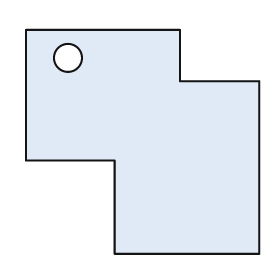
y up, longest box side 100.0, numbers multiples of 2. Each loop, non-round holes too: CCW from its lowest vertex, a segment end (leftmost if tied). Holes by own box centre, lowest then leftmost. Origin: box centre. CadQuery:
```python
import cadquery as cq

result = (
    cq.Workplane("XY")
    .moveTo(-12.0, -48.0)
    .lineTo(50.0, -48.0)
    .lineTo(50.0, 26.0)
    .lineTo(16.0, 26.0)
    .lineTo(16.0, 48.0)
    .lineTo(-50.0, 48.0)
    .lineTo(-50.0, -8.0)
    .lineTo(-12.0, -8.0)
    .close()
    .moveTo(-32.0, 36.0)
    .circle(6.0)
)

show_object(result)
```